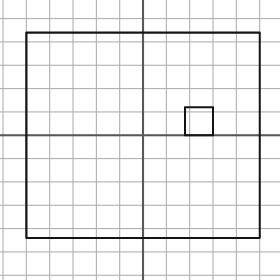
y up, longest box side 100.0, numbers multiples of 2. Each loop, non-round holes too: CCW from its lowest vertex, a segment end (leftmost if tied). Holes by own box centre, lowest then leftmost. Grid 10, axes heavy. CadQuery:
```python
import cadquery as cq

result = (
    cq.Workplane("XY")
    .moveTo(-50.0, -44.0)
    .lineTo(50.0, -44.0)
    .lineTo(50.0, 44.0)
    .lineTo(-50.0, 44.0)
    .close()
    .moveTo(18.0, 0.0)
    .lineTo(30.0, 0.0)
    .lineTo(30.0, 12.0)
    .lineTo(18.0, 12.0)
    .close()
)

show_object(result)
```